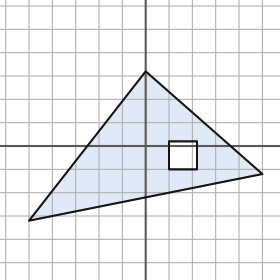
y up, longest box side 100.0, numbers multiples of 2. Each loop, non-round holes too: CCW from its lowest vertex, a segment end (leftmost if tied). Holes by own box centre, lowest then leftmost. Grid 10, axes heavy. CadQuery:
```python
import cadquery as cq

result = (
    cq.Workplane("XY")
    .moveTo(-50.0, -32.0)
    .lineTo(50.0, -12.0)
    .lineTo(0.0, 32.0)
    .close()
    .moveTo(10.0, -10.0)
    .lineTo(22.0, -10.0)
    .lineTo(22.0, 2.0)
    .lineTo(10.0, 2.0)
    .close()
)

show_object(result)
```